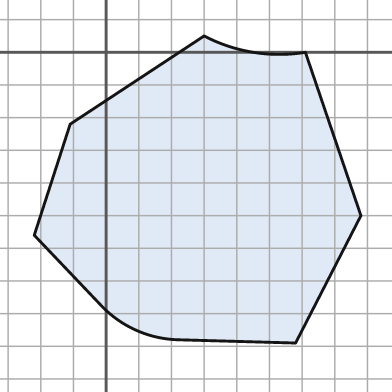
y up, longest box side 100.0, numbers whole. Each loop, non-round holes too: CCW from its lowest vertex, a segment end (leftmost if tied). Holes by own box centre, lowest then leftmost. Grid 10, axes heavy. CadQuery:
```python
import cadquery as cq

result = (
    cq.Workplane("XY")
    .moveTo(58.0, -89.0)
    .lineTo(78.0, -50.0)
    .lineTo(61.0, 0.0)
    .threePointArc((45.0, 0.0), (30.0, 5.0))
    .lineTo(-11.0, -22.0)
    .lineTo(-22.0, -56.0)
    .lineTo(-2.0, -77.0)
    .threePointArc((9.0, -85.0), (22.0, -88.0))
    .close()
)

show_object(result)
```